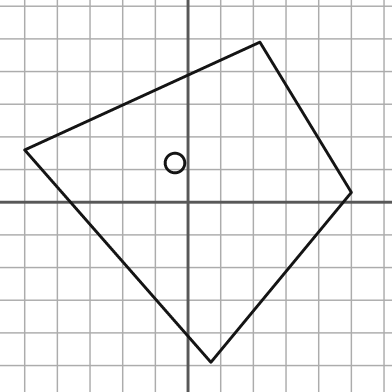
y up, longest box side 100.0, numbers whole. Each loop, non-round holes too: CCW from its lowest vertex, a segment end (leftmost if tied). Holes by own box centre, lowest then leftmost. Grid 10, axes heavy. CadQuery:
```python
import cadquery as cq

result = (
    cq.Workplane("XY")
    .moveTo(7.0, -49.0)
    .lineTo(50.0, 3.0)
    .lineTo(22.0, 49.0)
    .lineTo(-50.0, 16.0)
    .close()
    .moveTo(-4.0, 12.0)
    .circle(3.0)
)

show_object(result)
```